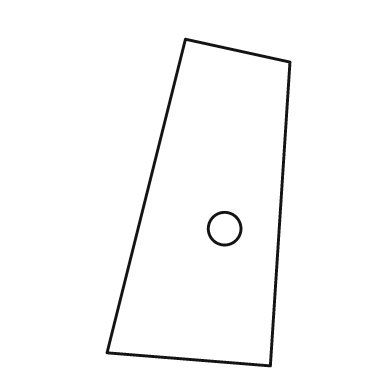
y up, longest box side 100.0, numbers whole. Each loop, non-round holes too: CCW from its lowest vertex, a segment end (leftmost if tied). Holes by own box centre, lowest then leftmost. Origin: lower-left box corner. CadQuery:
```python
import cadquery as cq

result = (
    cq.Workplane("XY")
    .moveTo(50.0, 0.0)
    .lineTo(56.0, 93.0)
    .lineTo(24.0, 100.0)
    .lineTo(0.0, 4.0)
    .close()
    .moveTo(36.0, 42.0)
    .circle(5.0)
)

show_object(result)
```